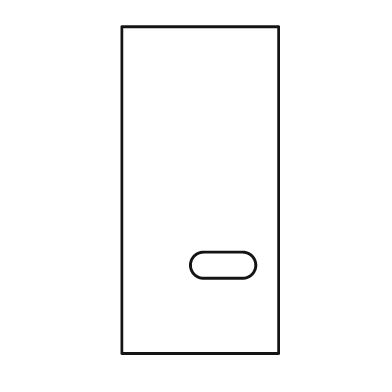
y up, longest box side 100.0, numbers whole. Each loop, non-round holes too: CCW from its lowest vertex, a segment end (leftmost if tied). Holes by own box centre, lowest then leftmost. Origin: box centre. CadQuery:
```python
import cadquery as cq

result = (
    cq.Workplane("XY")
    .moveTo(-24.0, -50.0)
    .lineTo(24.0, -50.0)
    .lineTo(24.0, 50.0)
    .lineTo(-24.0, 50.0)
    .close()
    .moveTo(1.0, -27.0)
    .lineTo(13.0, -27.0)
    .threePointArc((17.0, -23.0), (13.0, -19.0))
    .lineTo(1.0, -19.0)
    .threePointArc((-3.0, -23.0), (1.0, -27.0))
    .close()
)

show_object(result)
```